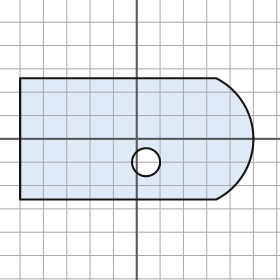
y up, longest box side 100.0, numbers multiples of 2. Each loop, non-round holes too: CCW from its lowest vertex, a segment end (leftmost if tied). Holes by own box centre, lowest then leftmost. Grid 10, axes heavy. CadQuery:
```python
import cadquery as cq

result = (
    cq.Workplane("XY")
    .moveTo(-50.0, -26.0)
    .lineTo(34.0, -26.0)
    .threePointArc((50.0, 0.0), (34.0, 26.0))
    .lineTo(-50.0, 26.0)
    .close()
    .moveTo(4.0, -10.0)
    .circle(6.0)
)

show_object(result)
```